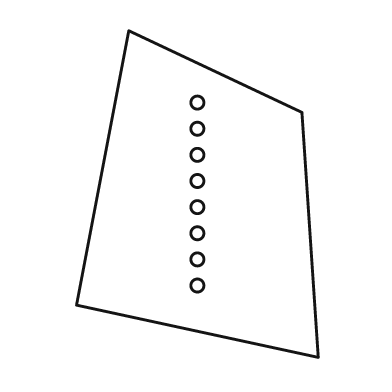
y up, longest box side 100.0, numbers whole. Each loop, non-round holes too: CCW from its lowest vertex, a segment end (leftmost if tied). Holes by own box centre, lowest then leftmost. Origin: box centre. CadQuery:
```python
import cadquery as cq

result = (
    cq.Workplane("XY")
    .moveTo(37.0, -50.0)
    .lineTo(32.0, 25.0)
    .lineTo(-21.0, 50.0)
    .lineTo(-37.0, -34.0)
    .close()
    .moveTo(0.0, -28.0)
    .circle(2.0)
    .moveTo(0.0, -20.0)
    .circle(2.0)
    .moveTo(0.0, -12.0)
    .circle(2.0)
    .moveTo(0.0, -4.0)
    .circle(2.0)
    .moveTo(0.0, 4.0)
    .circle(2.0)
    .moveTo(0.0, 12.0)
    .circle(2.0)
    .moveTo(0.0, 20.0)
    .circle(2.0)
    .moveTo(0.0, 28.0)
    .circle(2.0)
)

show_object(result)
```